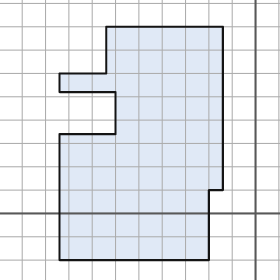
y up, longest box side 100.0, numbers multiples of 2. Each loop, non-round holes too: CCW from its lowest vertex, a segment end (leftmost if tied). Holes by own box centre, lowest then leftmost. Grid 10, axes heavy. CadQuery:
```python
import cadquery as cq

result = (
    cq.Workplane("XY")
    .moveTo(-84.0, -20.0)
    .lineTo(-20.0, -20.0)
    .lineTo(-20.0, 10.0)
    .lineTo(-14.0, 10.0)
    .lineTo(-14.0, 80.0)
    .lineTo(-64.0, 80.0)
    .lineTo(-64.0, 60.0)
    .lineTo(-84.0, 60.0)
    .lineTo(-84.0, 52.0)
    .lineTo(-60.0, 52.0)
    .lineTo(-60.0, 34.0)
    .lineTo(-84.0, 34.0)
    .close()
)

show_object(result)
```